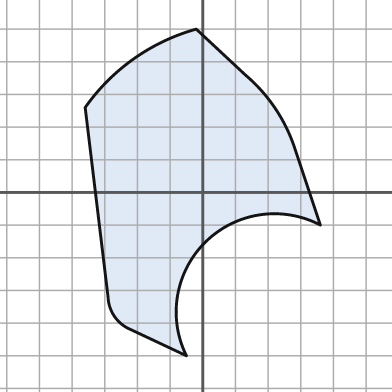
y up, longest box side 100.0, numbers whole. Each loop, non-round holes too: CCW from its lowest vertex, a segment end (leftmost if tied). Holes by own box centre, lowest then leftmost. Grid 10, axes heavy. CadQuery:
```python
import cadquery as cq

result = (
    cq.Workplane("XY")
    .moveTo(-5.0, -50.0)
    .threePointArc((1.0, -15.0), (36.0, -10.0))
    .lineTo(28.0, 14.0)
    .threePointArc((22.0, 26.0), (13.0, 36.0))
    .lineTo(-2.0, 50.0)
    .threePointArc((-21.0, 41.0), (-36.0, 26.0))
    .lineTo(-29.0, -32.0)
    .threePointArc((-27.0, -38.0), (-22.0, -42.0))
    .close()
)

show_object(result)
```